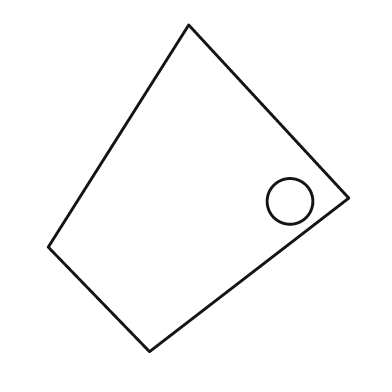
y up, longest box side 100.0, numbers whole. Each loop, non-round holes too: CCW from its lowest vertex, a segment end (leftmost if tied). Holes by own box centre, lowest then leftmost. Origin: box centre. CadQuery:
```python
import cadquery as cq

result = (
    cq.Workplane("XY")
    .moveTo(-15.0, -50.0)
    .lineTo(46.0, -3.0)
    .lineTo(-3.0, 50.0)
    .lineTo(-46.0, -18.0)
    .close()
    .moveTo(28.0, -4.0)
    .circle(7.0)
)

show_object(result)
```